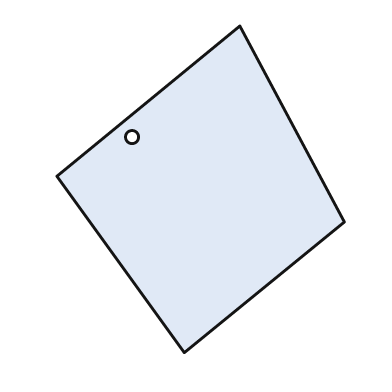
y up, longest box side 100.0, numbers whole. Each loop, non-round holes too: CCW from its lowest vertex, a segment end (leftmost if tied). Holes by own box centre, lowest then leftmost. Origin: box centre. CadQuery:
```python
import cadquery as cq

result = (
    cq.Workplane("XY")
    .moveTo(-5.0, -50.0)
    .lineTo(44.0, -10.0)
    .lineTo(12.0, 50.0)
    .lineTo(-44.0, 4.0)
    .close()
    .moveTo(-21.0, 16.0)
    .circle(2.0)
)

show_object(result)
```